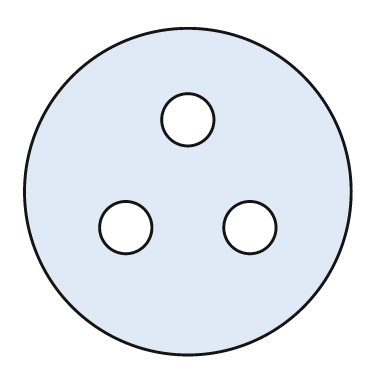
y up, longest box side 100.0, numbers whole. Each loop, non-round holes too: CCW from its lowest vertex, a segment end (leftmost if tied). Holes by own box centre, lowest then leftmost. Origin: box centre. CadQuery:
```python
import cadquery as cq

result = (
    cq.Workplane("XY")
    .moveTo(0.0, 0.0)
    .circle(50.0)
    .moveTo(-19.0, -11.0)
    .circle(8.0)
    .moveTo(19.0, -11.0)
    .circle(8.0)
    .moveTo(0.0, 22.0)
    .circle(8.0)
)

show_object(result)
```